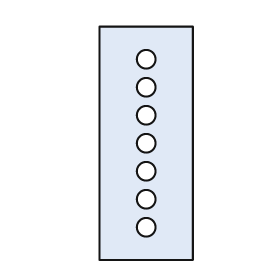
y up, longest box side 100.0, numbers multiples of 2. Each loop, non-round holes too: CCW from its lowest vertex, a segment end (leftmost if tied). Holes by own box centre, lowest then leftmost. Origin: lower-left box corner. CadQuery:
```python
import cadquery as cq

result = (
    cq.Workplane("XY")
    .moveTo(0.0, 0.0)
    .lineTo(40.0, 0.0)
    .lineTo(40.0, 100.0)
    .lineTo(0.0, 100.0)
    .close()
    .moveTo(20.0, 14.0)
    .circle(4.0)
    .moveTo(20.0, 26.0)
    .circle(4.0)
    .moveTo(20.0, 38.0)
    .circle(4.0)
    .moveTo(20.0, 50.0)
    .circle(4.0)
    .moveTo(20.0, 62.0)
    .circle(4.0)
    .moveTo(20.0, 74.0)
    .circle(4.0)
    .moveTo(20.0, 86.0)
    .circle(4.0)
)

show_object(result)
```